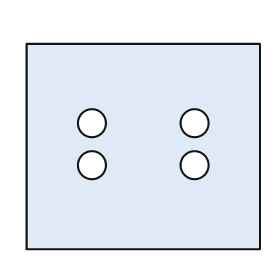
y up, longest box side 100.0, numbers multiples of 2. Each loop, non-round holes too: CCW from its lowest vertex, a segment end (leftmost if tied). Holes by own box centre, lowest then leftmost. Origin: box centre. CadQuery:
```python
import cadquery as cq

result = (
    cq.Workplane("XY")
    .moveTo(-50.0, -44.0)
    .lineTo(50.0, -44.0)
    .lineTo(50.0, 44.0)
    .lineTo(-50.0, 44.0)
    .close()
    .moveTo(-22.0, -8.0)
    .circle(6.0)
    .moveTo(22.0, -8.0)
    .circle(6.0)
    .moveTo(-22.0, 10.0)
    .circle(6.0)
    .moveTo(22.0, 10.0)
    .circle(6.0)
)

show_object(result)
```